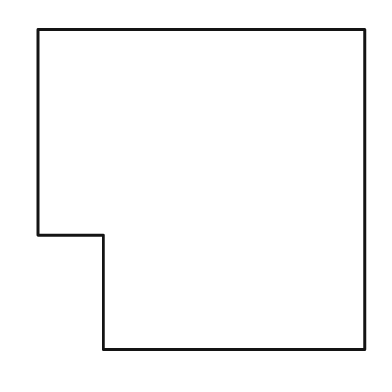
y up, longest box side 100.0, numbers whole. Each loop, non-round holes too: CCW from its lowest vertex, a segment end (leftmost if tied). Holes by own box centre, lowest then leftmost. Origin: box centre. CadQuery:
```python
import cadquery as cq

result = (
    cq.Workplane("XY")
    .moveTo(-30.0, -49.0)
    .lineTo(50.0, -49.0)
    .lineTo(50.0, 49.0)
    .lineTo(-50.0, 49.0)
    .lineTo(-50.0, -14.0)
    .lineTo(-30.0, -14.0)
    .close()
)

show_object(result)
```